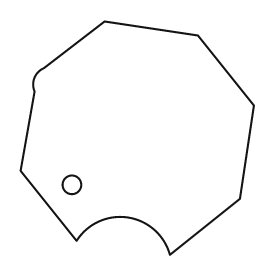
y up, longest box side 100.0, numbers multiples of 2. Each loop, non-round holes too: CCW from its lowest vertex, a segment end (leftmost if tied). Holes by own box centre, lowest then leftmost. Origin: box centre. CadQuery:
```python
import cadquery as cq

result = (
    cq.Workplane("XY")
    .moveTo(14.0, -50.0)
    .lineTo(44.0, -26.0)
    .lineTo(50.0, 14.0)
    .lineTo(26.0, 44.0)
    .lineTo(-14.0, 50.0)
    .lineTo(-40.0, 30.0)
    .threePointArc((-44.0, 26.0), (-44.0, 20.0))
    .lineTo(-50.0, -14.0)
    .lineTo(-26.0, -44.0)
    .threePointArc((-4.0, -34.0), (14.0, -50.0))
    .close()
    .moveTo(-28.0, -20.0)
    .circle(4.0)
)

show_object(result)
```